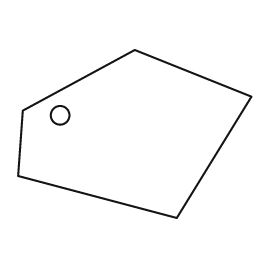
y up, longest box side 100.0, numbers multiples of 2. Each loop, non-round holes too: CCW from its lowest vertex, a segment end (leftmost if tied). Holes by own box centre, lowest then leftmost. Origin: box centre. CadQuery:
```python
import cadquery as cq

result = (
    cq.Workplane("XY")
    .moveTo(18.0, -36.0)
    .lineTo(50.0, 16.0)
    .lineTo(0.0, 36.0)
    .lineTo(-48.0, 10.0)
    .lineTo(-50.0, -18.0)
    .close()
    .moveTo(-32.0, 8.0)
    .circle(4.0)
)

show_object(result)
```